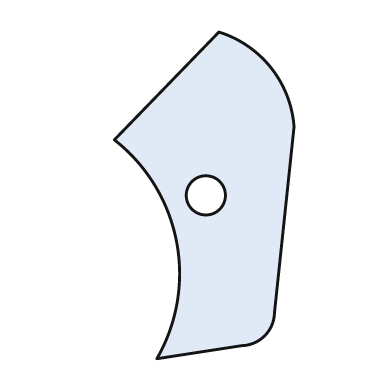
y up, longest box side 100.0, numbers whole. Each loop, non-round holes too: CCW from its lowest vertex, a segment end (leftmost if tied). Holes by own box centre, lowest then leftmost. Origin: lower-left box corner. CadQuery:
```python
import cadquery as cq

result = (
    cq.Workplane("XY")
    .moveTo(13.0, 0.0)
    .lineTo(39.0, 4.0)
    .threePointArc((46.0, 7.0), (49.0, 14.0))
    .lineTo(55.0, 71.0)
    .threePointArc((48.0, 89.0), (32.0, 100.0))
    .lineTo(0.0, 67.0)
    .threePointArc((19.0, 36.0), (13.0, 0.0))
    .close()
    .moveTo(28.0, 50.0)
    .circle(6.0)
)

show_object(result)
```